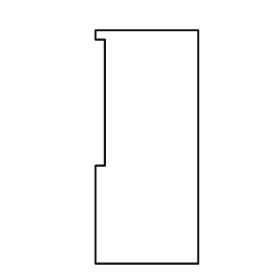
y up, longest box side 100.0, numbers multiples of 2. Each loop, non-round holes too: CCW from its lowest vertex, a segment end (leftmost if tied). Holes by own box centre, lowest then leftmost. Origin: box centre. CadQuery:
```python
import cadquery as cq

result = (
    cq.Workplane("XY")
    .moveTo(-22.0, -50.0)
    .lineTo(22.0, -50.0)
    .lineTo(22.0, 50.0)
    .lineTo(-22.0, 50.0)
    .lineTo(-22.0, 46.0)
    .lineTo(-18.0, 46.0)
    .lineTo(-18.0, -8.0)
    .lineTo(-22.0, -8.0)
    .close()
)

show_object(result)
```